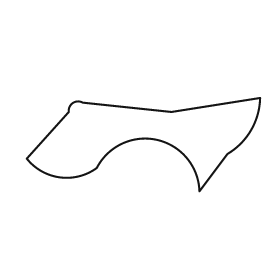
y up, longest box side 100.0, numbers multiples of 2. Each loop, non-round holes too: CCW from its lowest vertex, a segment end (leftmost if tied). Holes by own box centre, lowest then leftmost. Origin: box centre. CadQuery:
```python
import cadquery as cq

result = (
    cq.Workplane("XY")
    .moveTo(24.0, -20.0)
    .lineTo(36.0, -4.0)
    .threePointArc((46.0, 6.0), (50.0, 20.0))
    .lineTo(12.0, 14.0)
    .lineTo(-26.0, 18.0)
    .threePointArc((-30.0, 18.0), (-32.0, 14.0))
    .lineTo(-50.0, -6.0)
    .threePointArc((-36.0, -14.0), (-20.0, -10.0))
    .threePointArc((6.0, 2.0), (24.0, -20.0))
    .close()
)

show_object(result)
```